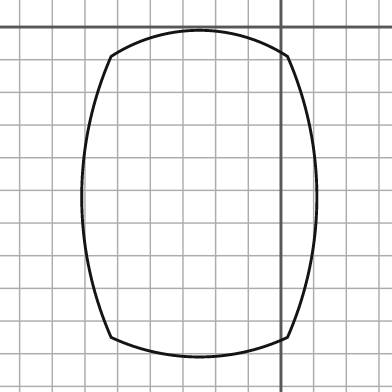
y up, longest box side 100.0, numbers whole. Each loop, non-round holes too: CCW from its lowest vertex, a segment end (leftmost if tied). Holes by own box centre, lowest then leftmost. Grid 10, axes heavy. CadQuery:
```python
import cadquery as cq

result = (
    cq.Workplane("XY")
    .moveTo(-52.0, -95.0)
    .threePointArc((-25.0, -101.0), (2.0, -95.0))
    .threePointArc((11.0, -52.0), (2.0, -9.0))
    .threePointArc((-25.0, -1.0), (-52.0, -9.0))
    .threePointArc((-61.0, -52.0), (-52.0, -95.0))
    .close()
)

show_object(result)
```